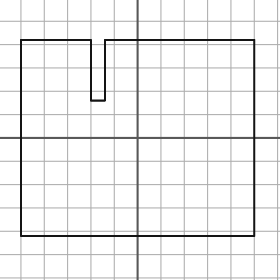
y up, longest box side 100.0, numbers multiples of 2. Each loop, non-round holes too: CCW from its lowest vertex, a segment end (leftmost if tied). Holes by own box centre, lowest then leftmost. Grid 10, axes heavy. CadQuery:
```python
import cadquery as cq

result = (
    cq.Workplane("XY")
    .moveTo(-50.0, -42.0)
    .lineTo(50.0, -42.0)
    .lineTo(50.0, 42.0)
    .lineTo(-14.0, 42.0)
    .lineTo(-14.0, 16.0)
    .lineTo(-20.0, 16.0)
    .lineTo(-20.0, 42.0)
    .lineTo(-50.0, 42.0)
    .close()
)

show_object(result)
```